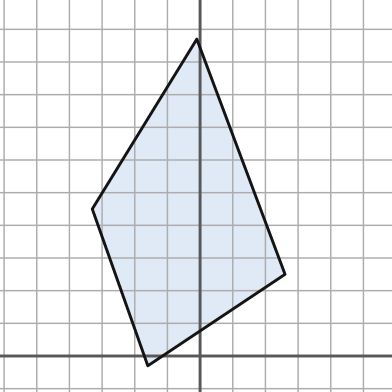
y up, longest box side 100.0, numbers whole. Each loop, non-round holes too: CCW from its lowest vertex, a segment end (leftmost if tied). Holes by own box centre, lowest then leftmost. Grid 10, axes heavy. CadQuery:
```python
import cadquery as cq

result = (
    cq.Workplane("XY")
    .moveTo(-16.0, -3.0)
    .lineTo(26.0, 25.0)
    .lineTo(-1.0, 97.0)
    .lineTo(-33.0, 45.0)
    .close()
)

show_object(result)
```